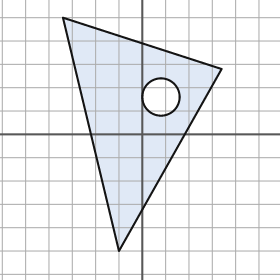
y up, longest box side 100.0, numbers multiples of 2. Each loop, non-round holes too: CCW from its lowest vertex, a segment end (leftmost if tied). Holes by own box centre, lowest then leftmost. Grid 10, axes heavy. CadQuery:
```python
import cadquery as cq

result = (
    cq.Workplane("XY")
    .moveTo(-10.0, -50.0)
    .lineTo(34.0, 28.0)
    .lineTo(-34.0, 50.0)
    .close()
    .moveTo(8.0, 16.0)
    .circle(8.0)
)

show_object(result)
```